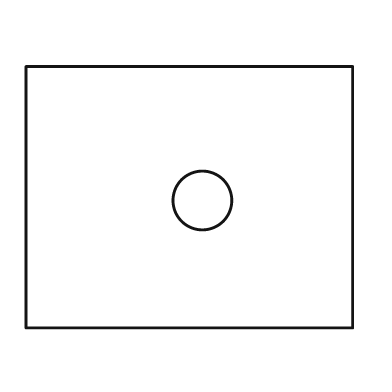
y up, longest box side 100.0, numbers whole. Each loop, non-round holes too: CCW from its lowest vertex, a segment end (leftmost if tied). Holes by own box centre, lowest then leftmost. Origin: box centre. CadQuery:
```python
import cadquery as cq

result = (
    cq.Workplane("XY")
    .moveTo(-50.0, -40.0)
    .lineTo(50.0, -40.0)
    .lineTo(50.0, 40.0)
    .lineTo(-50.0, 40.0)
    .close()
    .moveTo(4.0, -1.0)
    .circle(9.0)
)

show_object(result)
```